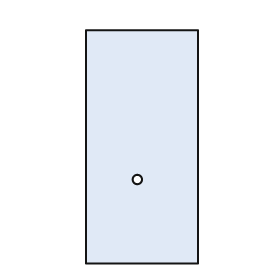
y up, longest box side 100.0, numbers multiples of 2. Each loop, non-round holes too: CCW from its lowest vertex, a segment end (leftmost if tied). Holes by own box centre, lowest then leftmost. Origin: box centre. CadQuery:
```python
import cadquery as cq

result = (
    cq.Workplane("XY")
    .moveTo(-24.0, -50.0)
    .lineTo(24.0, -50.0)
    .lineTo(24.0, 50.0)
    .lineTo(-24.0, 50.0)
    .close()
    .moveTo(-2.0, -14.0)
    .circle(2.0)
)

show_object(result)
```